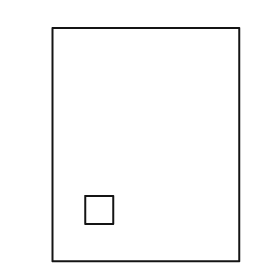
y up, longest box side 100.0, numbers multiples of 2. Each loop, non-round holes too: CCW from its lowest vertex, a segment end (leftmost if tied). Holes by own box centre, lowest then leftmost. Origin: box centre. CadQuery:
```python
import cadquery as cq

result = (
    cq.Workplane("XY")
    .moveTo(-40.0, -50.0)
    .lineTo(40.0, -50.0)
    .lineTo(40.0, 50.0)
    .lineTo(-40.0, 50.0)
    .close()
    .moveTo(-26.0, -34.0)
    .lineTo(-14.0, -34.0)
    .lineTo(-14.0, -22.0)
    .lineTo(-26.0, -22.0)
    .close()
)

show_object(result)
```